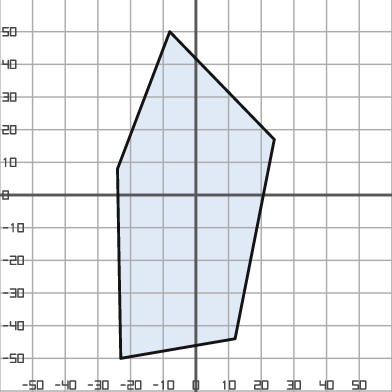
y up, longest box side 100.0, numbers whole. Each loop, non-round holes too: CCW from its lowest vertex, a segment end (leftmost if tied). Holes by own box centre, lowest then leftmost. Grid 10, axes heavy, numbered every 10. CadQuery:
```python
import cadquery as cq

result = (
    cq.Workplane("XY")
    .moveTo(-23.0, -50.0)
    .lineTo(12.0, -44.0)
    .lineTo(24.0, 17.0)
    .lineTo(-8.0, 50.0)
    .lineTo(-24.0, 8.0)
    .close()
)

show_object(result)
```